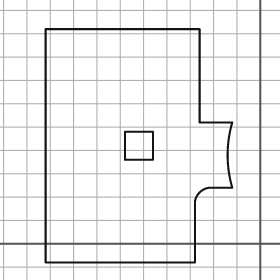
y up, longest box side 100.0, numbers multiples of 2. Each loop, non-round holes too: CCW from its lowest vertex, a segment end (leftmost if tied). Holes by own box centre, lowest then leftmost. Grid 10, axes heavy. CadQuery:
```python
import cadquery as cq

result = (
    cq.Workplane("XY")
    .moveTo(-92.0, -8.0)
    .lineTo(-28.0, -8.0)
    .lineTo(-28.0, 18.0)
    .threePointArc((-26.0, 22.0), (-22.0, 24.0))
    .lineTo(-12.0, 24.0)
    .threePointArc((-14.0, 38.0), (-12.0, 52.0))
    .lineTo(-26.0, 52.0)
    .lineTo(-26.0, 92.0)
    .lineTo(-92.0, 92.0)
    .close()
    .moveTo(-58.0, 36.0)
    .lineTo(-46.0, 36.0)
    .lineTo(-46.0, 48.0)
    .lineTo(-58.0, 48.0)
    .close()
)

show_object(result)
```